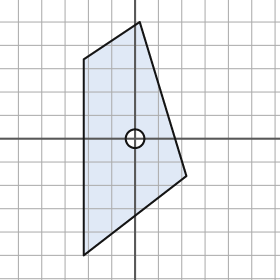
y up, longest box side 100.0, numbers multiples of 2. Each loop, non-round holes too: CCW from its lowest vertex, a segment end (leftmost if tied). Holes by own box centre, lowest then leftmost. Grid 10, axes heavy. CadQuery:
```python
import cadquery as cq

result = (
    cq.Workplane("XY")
    .moveTo(-22.0, -50.0)
    .lineTo(22.0, -16.0)
    .lineTo(2.0, 50.0)
    .lineTo(-22.0, 34.0)
    .close()
    .moveTo(0.0, 0.0)
    .circle(4.0)
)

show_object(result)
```